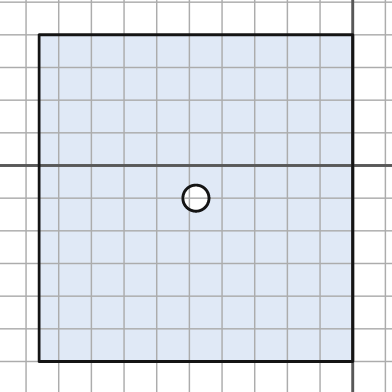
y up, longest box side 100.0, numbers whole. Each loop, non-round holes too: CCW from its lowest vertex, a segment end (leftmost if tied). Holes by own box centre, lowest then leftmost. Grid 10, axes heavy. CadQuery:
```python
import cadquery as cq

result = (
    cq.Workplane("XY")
    .moveTo(-96.0, -60.0)
    .lineTo(0.0, -60.0)
    .lineTo(0.0, 40.0)
    .lineTo(-96.0, 40.0)
    .close()
    .moveTo(-48.0, -10.0)
    .circle(4.0)
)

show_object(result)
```